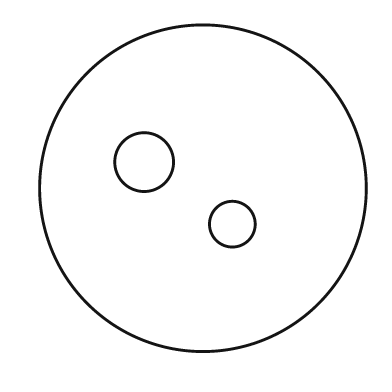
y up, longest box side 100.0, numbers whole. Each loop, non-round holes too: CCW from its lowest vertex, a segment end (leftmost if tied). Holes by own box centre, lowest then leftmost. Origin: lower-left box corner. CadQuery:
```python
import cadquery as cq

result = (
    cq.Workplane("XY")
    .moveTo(50.0, 50.0)
    .circle(50.0)
    .moveTo(59.0, 39.0)
    .circle(7.0)
    .moveTo(32.0, 58.0)
    .circle(9.0)
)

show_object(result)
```